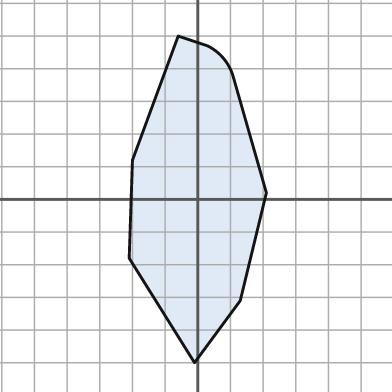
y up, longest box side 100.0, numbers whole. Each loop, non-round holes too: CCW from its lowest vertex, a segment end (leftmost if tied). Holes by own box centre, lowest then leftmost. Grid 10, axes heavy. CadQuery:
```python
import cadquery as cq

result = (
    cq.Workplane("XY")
    .moveTo(-1.0, -50.0)
    .lineTo(13.0, -31.0)
    .lineTo(21.0, 2.0)
    .lineTo(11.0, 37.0)
    .threePointArc((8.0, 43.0), (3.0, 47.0))
    .lineTo(-6.0, 50.0)
    .lineTo(-20.0, 12.0)
    .lineTo(-21.0, -18.0)
    .close()
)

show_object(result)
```